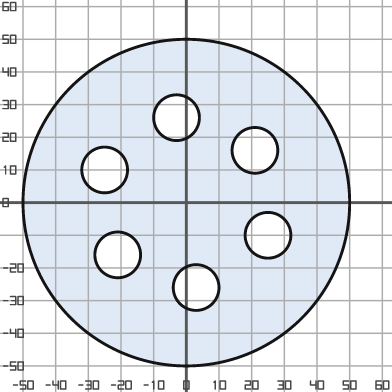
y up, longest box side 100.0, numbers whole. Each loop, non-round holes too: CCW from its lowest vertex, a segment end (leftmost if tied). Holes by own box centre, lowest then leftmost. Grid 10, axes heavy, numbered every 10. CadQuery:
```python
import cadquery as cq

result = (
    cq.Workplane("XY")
    .moveTo(0.0, 0.0)
    .circle(50.0)
    .moveTo(3.0, -26.0)
    .circle(7.0)
    .moveTo(-21.0, -16.0)
    .circle(7.0)
    .moveTo(25.0, -10.0)
    .circle(7.0)
    .moveTo(-25.0, 10.0)
    .circle(7.0)
    .moveTo(21.0, 16.0)
    .circle(7.0)
    .moveTo(-3.0, 26.0)
    .circle(7.0)
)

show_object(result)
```